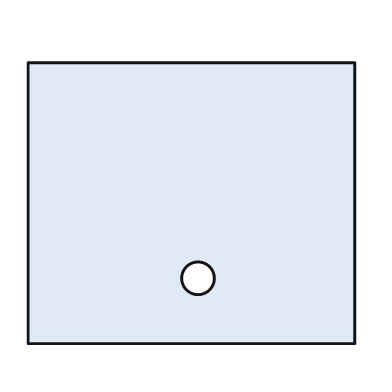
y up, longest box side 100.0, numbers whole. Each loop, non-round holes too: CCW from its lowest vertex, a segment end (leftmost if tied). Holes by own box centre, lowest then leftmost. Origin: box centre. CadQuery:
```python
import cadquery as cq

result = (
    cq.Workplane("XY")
    .moveTo(-50.0, -43.0)
    .lineTo(50.0, -43.0)
    .lineTo(50.0, 43.0)
    .lineTo(-50.0, 43.0)
    .close()
    .moveTo(2.0, -23.0)
    .circle(5.0)
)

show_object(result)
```